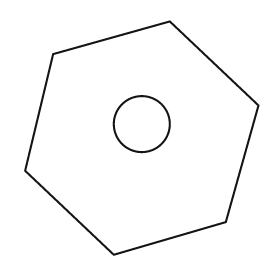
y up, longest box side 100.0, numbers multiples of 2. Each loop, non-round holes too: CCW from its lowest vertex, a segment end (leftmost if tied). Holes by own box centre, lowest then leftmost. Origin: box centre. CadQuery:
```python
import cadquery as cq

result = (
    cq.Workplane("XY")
    .moveTo(-12.0, -50.0)
    .lineTo(36.0, -36.0)
    .lineTo(50.0, 14.0)
    .lineTo(12.0, 50.0)
    .lineTo(-38.0, 36.0)
    .lineTo(-50.0, -14.0)
    .close()
    .moveTo(0.0, 6.0)
    .circle(12.0)
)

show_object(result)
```